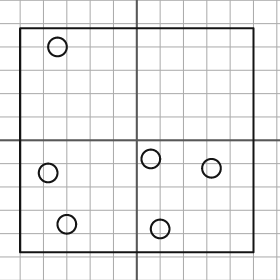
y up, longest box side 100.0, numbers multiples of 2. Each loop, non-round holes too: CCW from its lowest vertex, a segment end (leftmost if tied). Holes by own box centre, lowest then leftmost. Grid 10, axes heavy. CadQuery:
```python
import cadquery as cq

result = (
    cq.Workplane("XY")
    .moveTo(-50.0, -48.0)
    .lineTo(50.0, -48.0)
    .lineTo(50.0, 48.0)
    .lineTo(-50.0, 48.0)
    .close()
    .moveTo(10.0, -38.0)
    .circle(4.0)
    .moveTo(-30.0, -36.0)
    .circle(4.0)
    .moveTo(-38.0, -14.0)
    .circle(4.0)
    .moveTo(32.0, -12.0)
    .circle(4.0)
    .moveTo(6.0, -8.0)
    .circle(4.0)
    .moveTo(-34.0, 40.0)
    .circle(4.0)
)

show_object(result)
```